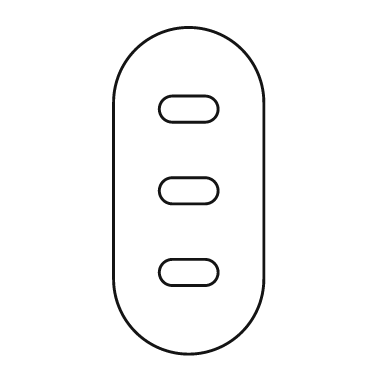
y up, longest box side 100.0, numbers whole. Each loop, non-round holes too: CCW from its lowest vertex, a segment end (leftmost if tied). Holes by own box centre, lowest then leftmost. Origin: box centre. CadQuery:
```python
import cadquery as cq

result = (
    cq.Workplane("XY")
    .moveTo(-23.0, -27.0)
    .threePointArc((0.0, -50.0), (23.0, -27.0))
    .lineTo(23.0, 27.0)
    .threePointArc((0.0, 50.0), (-23.0, 27.0))
    .close()
    .moveTo(-5.0, -29.0)
    .lineTo(5.0, -29.0)
    .threePointArc((9.0, -25.0), (5.0, -21.0))
    .lineTo(-5.0, -21.0)
    .threePointArc((-9.0, -25.0), (-5.0, -29.0))
    .close()
    .moveTo(-5.0, -4.0)
    .lineTo(5.0, -4.0)
    .threePointArc((9.0, 0.0), (5.0, 4.0))
    .lineTo(-5.0, 4.0)
    .threePointArc((-9.0, 0.0), (-5.0, -4.0))
    .close()
    .moveTo(-5.0, 21.0)
    .lineTo(5.0, 21.0)
    .threePointArc((9.0, 25.0), (5.0, 29.0))
    .lineTo(-5.0, 29.0)
    .threePointArc((-9.0, 25.0), (-5.0, 21.0))
    .close()
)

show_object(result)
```